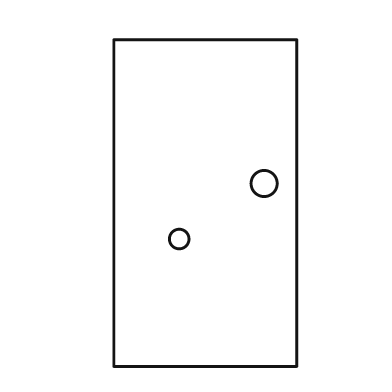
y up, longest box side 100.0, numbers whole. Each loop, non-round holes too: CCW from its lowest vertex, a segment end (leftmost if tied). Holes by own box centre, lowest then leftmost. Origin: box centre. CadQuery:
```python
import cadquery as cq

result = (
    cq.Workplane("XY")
    .moveTo(-28.0, -50.0)
    .lineTo(28.0, -50.0)
    .lineTo(28.0, 50.0)
    .lineTo(-28.0, 50.0)
    .close()
    .moveTo(-8.0, -11.0)
    .circle(3.0)
    .moveTo(18.0, 6.0)
    .circle(4.0)
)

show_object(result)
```